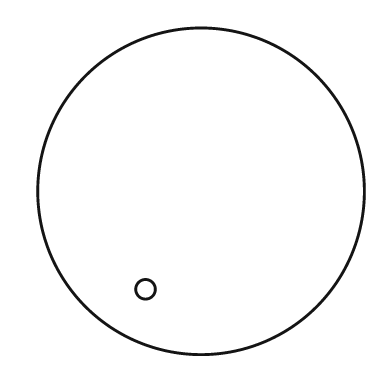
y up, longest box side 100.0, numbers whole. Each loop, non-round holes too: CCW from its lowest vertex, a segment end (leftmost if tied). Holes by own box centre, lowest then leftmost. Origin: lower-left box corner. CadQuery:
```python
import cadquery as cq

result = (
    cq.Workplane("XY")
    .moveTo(50.0, 50.0)
    .circle(50.0)
    .moveTo(33.0, 20.0)
    .circle(3.0)
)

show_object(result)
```